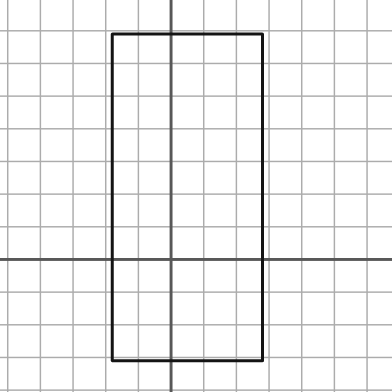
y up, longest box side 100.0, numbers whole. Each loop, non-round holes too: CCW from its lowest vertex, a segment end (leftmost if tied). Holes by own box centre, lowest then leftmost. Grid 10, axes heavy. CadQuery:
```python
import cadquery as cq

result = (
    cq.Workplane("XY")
    .moveTo(-18.0, -31.0)
    .lineTo(28.0, -31.0)
    .lineTo(28.0, 69.0)
    .lineTo(-18.0, 69.0)
    .close()
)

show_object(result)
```